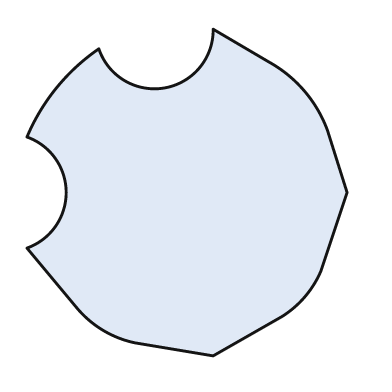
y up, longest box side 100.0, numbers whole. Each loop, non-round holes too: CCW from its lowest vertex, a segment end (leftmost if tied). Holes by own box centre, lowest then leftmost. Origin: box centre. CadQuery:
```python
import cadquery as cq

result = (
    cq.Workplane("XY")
    .moveTo(8.0, -50.0)
    .lineTo(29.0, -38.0)
    .threePointArc((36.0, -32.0), (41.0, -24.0))
    .lineTo(49.0, 0.0)
    .lineTo(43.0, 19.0)
    .threePointArc((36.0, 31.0), (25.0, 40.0))
    .lineTo(8.0, 50.0)
    .threePointArc((-7.0, 32.0), (-27.0, 44.0))
    .threePointArc((-40.0, 32.0), (-49.0, 17.0))
    .threePointArc((-37.0, 0.0), (-49.0, -17.0))
    .lineTo(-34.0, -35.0)
    .threePointArc((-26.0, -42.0), (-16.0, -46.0))
    .close()
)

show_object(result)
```